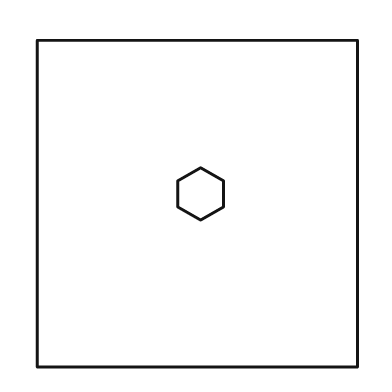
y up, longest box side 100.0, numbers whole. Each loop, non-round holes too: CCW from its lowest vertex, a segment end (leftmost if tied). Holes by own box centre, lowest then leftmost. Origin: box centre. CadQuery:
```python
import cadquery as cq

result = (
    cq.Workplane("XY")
    .moveTo(-49.0, -50.0)
    .lineTo(49.0, -50.0)
    .lineTo(49.0, 50.0)
    .lineTo(-49.0, 50.0)
    .close()
    .moveTo(1.0, -5.0)
    .lineTo(8.0, -1.0)
    .lineTo(8.0, 7.0)
    .lineTo(1.0, 11.0)
    .lineTo(-6.0, 7.0)
    .lineTo(-6.0, -1.0)
    .close()
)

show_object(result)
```